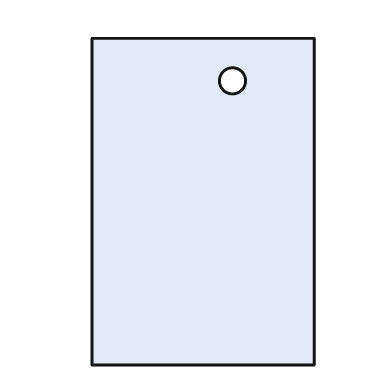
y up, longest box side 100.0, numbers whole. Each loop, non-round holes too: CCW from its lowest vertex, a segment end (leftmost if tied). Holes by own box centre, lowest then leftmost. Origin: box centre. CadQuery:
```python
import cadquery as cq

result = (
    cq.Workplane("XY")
    .moveTo(-34.0, -50.0)
    .lineTo(34.0, -50.0)
    .lineTo(34.0, 50.0)
    .lineTo(-34.0, 50.0)
    .close()
    .moveTo(9.0, 37.0)
    .circle(4.0)
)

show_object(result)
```